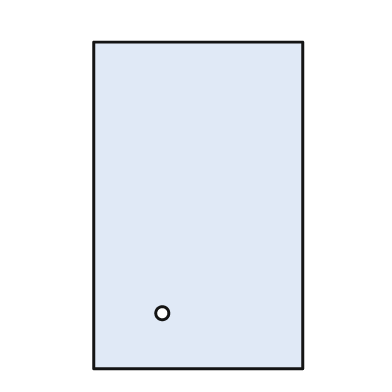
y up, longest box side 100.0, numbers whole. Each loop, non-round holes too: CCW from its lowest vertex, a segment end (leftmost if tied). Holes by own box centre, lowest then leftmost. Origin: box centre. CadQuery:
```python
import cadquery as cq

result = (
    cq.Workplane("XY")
    .moveTo(-32.0, -50.0)
    .lineTo(32.0, -50.0)
    .lineTo(32.0, 50.0)
    .lineTo(-32.0, 50.0)
    .close()
    .moveTo(-11.0, -33.0)
    .circle(2.0)
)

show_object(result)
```